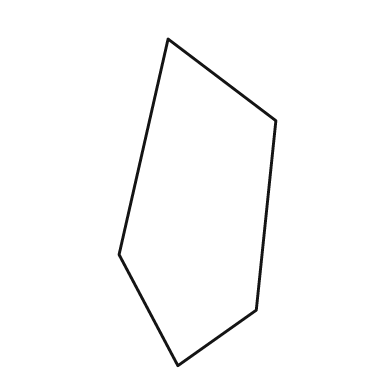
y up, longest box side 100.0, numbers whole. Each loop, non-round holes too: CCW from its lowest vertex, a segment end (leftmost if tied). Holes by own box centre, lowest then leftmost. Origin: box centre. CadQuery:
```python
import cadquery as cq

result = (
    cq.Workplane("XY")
    .moveTo(-6.0, -50.0)
    .lineTo(18.0, -33.0)
    .lineTo(24.0, 25.0)
    .lineTo(-9.0, 50.0)
    .lineTo(-24.0, -16.0)
    .close()
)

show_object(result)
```